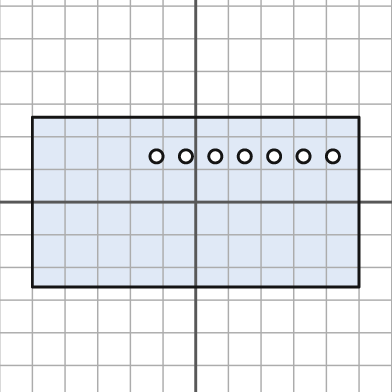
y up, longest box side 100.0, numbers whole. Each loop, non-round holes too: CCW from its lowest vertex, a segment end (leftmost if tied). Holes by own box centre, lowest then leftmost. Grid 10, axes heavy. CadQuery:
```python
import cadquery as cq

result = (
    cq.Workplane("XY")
    .moveTo(-50.0, -26.0)
    .lineTo(50.0, -26.0)
    .lineTo(50.0, 26.0)
    .lineTo(-50.0, 26.0)
    .close()
    .moveTo(-12.0, 14.0)
    .circle(2.0)
    .moveTo(-3.0, 14.0)
    .circle(2.0)
    .moveTo(6.0, 14.0)
    .circle(2.0)
    .moveTo(15.0, 14.0)
    .circle(2.0)
    .moveTo(24.0, 14.0)
    .circle(2.0)
    .moveTo(33.0, 14.0)
    .circle(2.0)
    .moveTo(42.0, 14.0)
    .circle(2.0)
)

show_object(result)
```